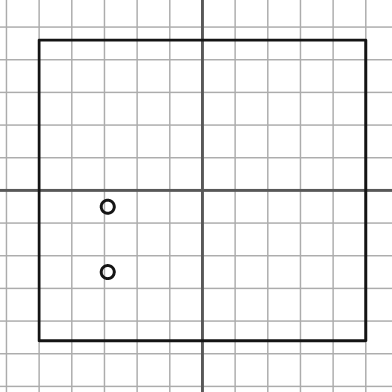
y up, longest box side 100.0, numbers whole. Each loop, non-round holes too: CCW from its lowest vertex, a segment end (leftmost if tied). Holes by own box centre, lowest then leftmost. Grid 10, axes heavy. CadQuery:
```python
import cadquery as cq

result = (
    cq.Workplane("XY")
    .moveTo(-50.0, -46.0)
    .lineTo(50.0, -46.0)
    .lineTo(50.0, 46.0)
    .lineTo(-50.0, 46.0)
    .close()
    .moveTo(-29.0, -25.0)
    .circle(2.0)
    .moveTo(-29.0, -5.0)
    .circle(2.0)
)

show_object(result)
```